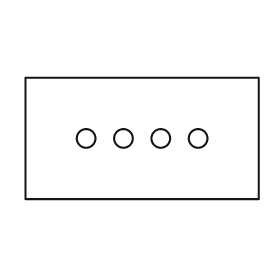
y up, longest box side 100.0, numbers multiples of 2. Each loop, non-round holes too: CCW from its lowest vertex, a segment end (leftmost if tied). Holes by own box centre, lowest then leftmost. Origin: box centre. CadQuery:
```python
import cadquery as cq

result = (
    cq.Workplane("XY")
    .moveTo(-50.0, -26.0)
    .lineTo(50.0, -26.0)
    .lineTo(50.0, 26.0)
    .lineTo(-50.0, 26.0)
    .close()
    .moveTo(-24.0, 0.0)
    .circle(4.0)
    .moveTo(-8.0, 0.0)
    .circle(4.0)
    .moveTo(8.0, 0.0)
    .circle(4.0)
    .moveTo(24.0, 0.0)
    .circle(4.0)
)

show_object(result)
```